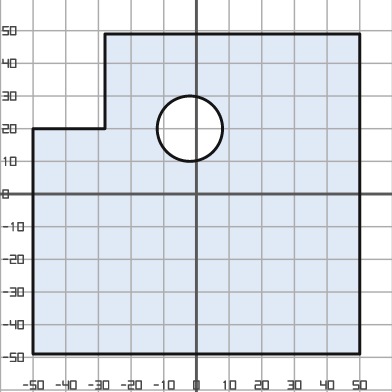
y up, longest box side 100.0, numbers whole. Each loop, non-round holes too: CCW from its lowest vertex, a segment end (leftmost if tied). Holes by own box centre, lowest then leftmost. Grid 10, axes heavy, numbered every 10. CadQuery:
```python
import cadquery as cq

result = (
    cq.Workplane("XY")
    .moveTo(-50.0, -49.0)
    .lineTo(50.0, -49.0)
    .lineTo(50.0, 49.0)
    .lineTo(-28.0, 49.0)
    .lineTo(-28.0, 20.0)
    .lineTo(-50.0, 20.0)
    .close()
    .moveTo(-2.0, 20.0)
    .circle(10.0)
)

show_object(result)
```